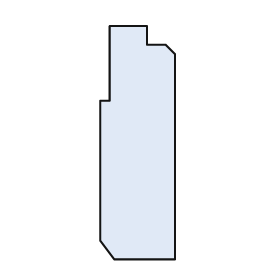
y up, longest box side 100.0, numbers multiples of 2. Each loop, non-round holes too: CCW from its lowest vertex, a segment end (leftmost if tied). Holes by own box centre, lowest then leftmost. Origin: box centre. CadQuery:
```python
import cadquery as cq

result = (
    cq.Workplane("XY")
    .moveTo(-10.0, -50.0)
    .lineTo(16.0, -50.0)
    .lineTo(16.0, 38.0)
    .lineTo(12.0, 42.0)
    .lineTo(4.0, 42.0)
    .lineTo(4.0, 50.0)
    .lineTo(-12.0, 50.0)
    .lineTo(-12.0, 18.0)
    .lineTo(-16.0, 18.0)
    .lineTo(-16.0, -42.0)
    .close()
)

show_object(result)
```